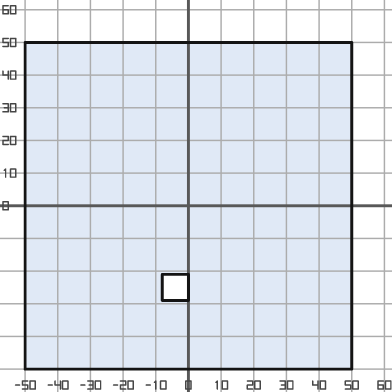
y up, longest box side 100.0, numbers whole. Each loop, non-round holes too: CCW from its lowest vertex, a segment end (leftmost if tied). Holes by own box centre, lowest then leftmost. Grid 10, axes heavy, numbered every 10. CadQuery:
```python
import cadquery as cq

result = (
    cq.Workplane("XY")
    .moveTo(-50.0, -50.0)
    .lineTo(50.0, -50.0)
    .lineTo(50.0, 50.0)
    .lineTo(-50.0, 50.0)
    .close()
    .moveTo(-8.0, -29.0)
    .lineTo(0.0, -29.0)
    .lineTo(0.0, -21.0)
    .lineTo(-8.0, -21.0)
    .close()
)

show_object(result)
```